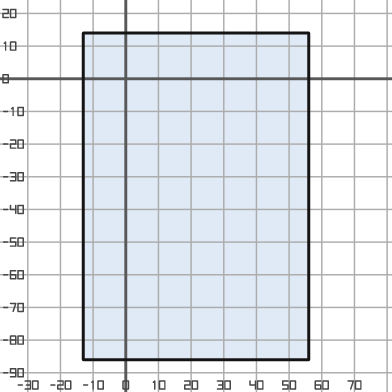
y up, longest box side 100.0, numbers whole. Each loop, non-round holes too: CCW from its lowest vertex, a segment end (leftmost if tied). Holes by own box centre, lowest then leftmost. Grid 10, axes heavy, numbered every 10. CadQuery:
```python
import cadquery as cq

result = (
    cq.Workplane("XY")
    .moveTo(-13.0, -86.0)
    .lineTo(56.0, -86.0)
    .lineTo(56.0, 14.0)
    .lineTo(-13.0, 14.0)
    .close()
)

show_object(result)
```